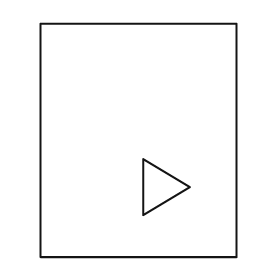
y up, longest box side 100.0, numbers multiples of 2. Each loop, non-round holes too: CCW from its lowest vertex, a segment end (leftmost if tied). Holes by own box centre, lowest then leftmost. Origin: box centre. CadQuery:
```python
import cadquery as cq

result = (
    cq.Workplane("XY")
    .moveTo(-42.0, -50.0)
    .lineTo(42.0, -50.0)
    .lineTo(42.0, 50.0)
    .lineTo(-42.0, 50.0)
    .close()
    .moveTo(2.0, -32.0)
    .lineTo(22.0, -20.0)
    .lineTo(2.0, -8.0)
    .close()
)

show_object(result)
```